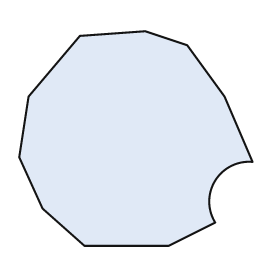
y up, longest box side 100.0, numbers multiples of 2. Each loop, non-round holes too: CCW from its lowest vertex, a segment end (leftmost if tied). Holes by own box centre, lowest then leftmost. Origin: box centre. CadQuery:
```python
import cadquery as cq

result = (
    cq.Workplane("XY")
    .moveTo(-22.0, -46.0)
    .lineTo(14.0, -46.0)
    .lineTo(34.0, -36.0)
    .threePointArc((34.0, -18.0), (50.0, -10.0))
    .lineTo(38.0, 18.0)
    .lineTo(22.0, 40.0)
    .lineTo(4.0, 46.0)
    .lineTo(-24.0, 44.0)
    .lineTo(-46.0, 18.0)
    .lineTo(-50.0, -8.0)
    .lineTo(-40.0, -30.0)
    .close()
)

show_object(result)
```